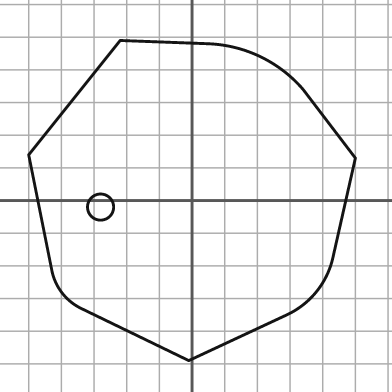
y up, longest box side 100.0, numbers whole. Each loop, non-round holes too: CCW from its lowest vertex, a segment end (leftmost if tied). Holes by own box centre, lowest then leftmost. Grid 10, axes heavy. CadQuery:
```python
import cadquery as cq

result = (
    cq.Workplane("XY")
    .moveTo(-1.0, -49.0)
    .lineTo(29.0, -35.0)
    .threePointArc((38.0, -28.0), (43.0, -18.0))
    .lineTo(50.0, 13.0)
    .lineTo(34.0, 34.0)
    .threePointArc((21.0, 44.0), (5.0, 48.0))
    .lineTo(-22.0, 49.0)
    .lineTo(-50.0, 14.0)
    .lineTo(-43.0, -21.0)
    .threePointArc((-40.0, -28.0), (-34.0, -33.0))
    .close()
    .moveTo(-28.0, -2.0)
    .circle(4.0)
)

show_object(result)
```